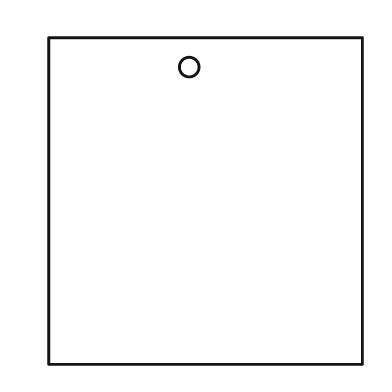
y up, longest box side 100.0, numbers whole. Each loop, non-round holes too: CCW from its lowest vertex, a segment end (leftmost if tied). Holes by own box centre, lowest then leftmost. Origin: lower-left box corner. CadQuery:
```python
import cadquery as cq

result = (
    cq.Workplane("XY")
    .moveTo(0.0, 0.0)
    .lineTo(96.0, 0.0)
    .lineTo(96.0, 100.0)
    .lineTo(0.0, 100.0)
    .close()
    .moveTo(43.0, 91.0)
    .circle(3.0)
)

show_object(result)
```